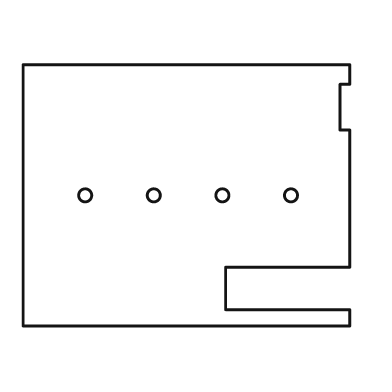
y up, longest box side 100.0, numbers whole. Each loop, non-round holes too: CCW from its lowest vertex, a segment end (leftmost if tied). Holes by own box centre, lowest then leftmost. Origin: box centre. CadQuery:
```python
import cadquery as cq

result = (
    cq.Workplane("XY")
    .moveTo(-50.0, -40.0)
    .lineTo(50.0, -40.0)
    .lineTo(50.0, -35.0)
    .lineTo(12.0, -35.0)
    .lineTo(12.0, -22.0)
    .lineTo(50.0, -22.0)
    .lineTo(50.0, 20.0)
    .lineTo(47.0, 20.0)
    .lineTo(47.0, 34.0)
    .lineTo(50.0, 34.0)
    .lineTo(50.0, 40.0)
    .lineTo(-50.0, 40.0)
    .close()
    .moveTo(-31.0, 0.0)
    .circle(2.0)
    .moveTo(-10.0, 0.0)
    .circle(2.0)
    .moveTo(11.0, 0.0)
    .circle(2.0)
    .moveTo(32.0, 0.0)
    .circle(2.0)
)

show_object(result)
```